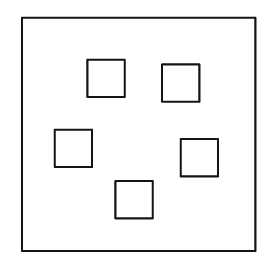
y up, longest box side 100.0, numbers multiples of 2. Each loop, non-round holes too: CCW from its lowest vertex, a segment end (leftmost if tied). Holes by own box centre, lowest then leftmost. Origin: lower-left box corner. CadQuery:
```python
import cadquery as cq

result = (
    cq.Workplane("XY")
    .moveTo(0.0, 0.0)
    .lineTo(100.0, 0.0)
    .lineTo(100.0, 100.0)
    .lineTo(0.0, 100.0)
    .close()
    .moveTo(40.0, 14.0)
    .lineTo(56.0, 14.0)
    .lineTo(56.0, 30.0)
    .lineTo(40.0, 30.0)
    .close()
    .moveTo(68.0, 32.0)
    .lineTo(84.0, 32.0)
    .lineTo(84.0, 48.0)
    .lineTo(68.0, 48.0)
    .close()
    .moveTo(14.0, 36.0)
    .lineTo(30.0, 36.0)
    .lineTo(30.0, 52.0)
    .lineTo(14.0, 52.0)
    .close()
    .moveTo(60.0, 64.0)
    .lineTo(76.0, 64.0)
    .lineTo(76.0, 80.0)
    .lineTo(60.0, 80.0)
    .close()
    .moveTo(28.0, 66.0)
    .lineTo(44.0, 66.0)
    .lineTo(44.0, 82.0)
    .lineTo(28.0, 82.0)
    .close()
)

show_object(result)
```